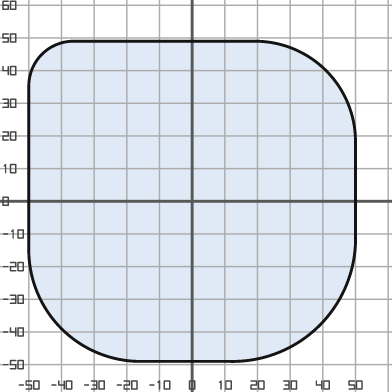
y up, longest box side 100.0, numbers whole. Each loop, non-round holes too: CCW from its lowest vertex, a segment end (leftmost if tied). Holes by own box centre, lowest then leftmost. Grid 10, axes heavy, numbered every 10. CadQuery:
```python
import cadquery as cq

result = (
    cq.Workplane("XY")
    .moveTo(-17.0, -49.0)
    .lineTo(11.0, -49.0)
    .threePointArc((39.0, -38.0), (50.0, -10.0))
    .lineTo(50.0, 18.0)
    .threePointArc((41.0, 40.0), (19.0, 49.0))
    .lineTo(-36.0, 49.0)
    .threePointArc((-46.0, 45.0), (-50.0, 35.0))
    .lineTo(-50.0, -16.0)
    .threePointArc((-40.0, -39.0), (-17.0, -49.0))
    .close()
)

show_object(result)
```